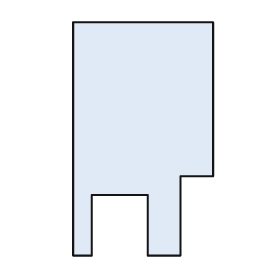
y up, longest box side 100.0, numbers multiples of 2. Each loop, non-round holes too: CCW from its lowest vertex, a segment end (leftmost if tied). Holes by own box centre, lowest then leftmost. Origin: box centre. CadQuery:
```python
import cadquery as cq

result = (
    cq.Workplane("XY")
    .moveTo(-30.0, -50.0)
    .lineTo(-22.0, -50.0)
    .lineTo(-22.0, -24.0)
    .lineTo(2.0, -24.0)
    .lineTo(2.0, -50.0)
    .lineTo(16.0, -50.0)
    .lineTo(16.0, -16.0)
    .lineTo(30.0, -16.0)
    .lineTo(30.0, 50.0)
    .lineTo(-30.0, 50.0)
    .close()
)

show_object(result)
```